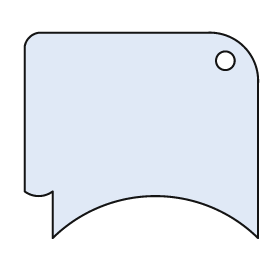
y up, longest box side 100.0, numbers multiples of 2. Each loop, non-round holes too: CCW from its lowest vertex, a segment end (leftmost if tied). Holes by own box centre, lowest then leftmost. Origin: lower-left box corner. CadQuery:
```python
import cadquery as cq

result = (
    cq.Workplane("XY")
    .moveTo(12.0, 0.0)
    .threePointArc((56.0, 18.0), (100.0, 0.0))
    .lineTo(100.0, 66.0)
    .threePointArc((94.0, 82.0), (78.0, 88.0))
    .lineTo(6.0, 88.0)
    .threePointArc((2.0, 86.0), (0.0, 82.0))
    .lineTo(0.0, 20.0)
    .threePointArc((6.0, 18.0), (12.0, 20.0))
    .close()
    .moveTo(86.0, 76.0)
    .circle(4.0)
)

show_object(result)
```